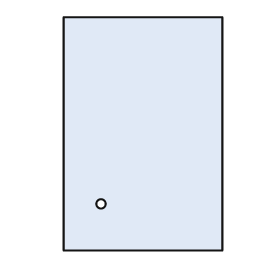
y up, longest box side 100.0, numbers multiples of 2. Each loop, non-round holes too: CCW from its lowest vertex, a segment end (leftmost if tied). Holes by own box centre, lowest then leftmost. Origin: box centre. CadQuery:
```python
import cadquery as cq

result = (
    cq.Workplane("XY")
    .moveTo(-34.0, -50.0)
    .lineTo(34.0, -50.0)
    .lineTo(34.0, 50.0)
    .lineTo(-34.0, 50.0)
    .close()
    .moveTo(-18.0, -30.0)
    .circle(2.0)
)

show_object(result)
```